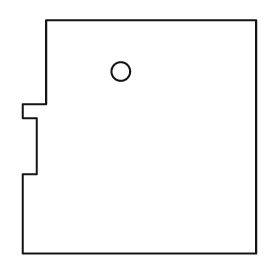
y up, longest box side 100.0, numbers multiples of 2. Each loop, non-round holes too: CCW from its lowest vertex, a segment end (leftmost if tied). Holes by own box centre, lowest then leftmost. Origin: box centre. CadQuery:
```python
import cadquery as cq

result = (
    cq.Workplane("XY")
    .moveTo(-50.0, -50.0)
    .lineTo(50.0, -50.0)
    .lineTo(50.0, 50.0)
    .lineTo(-40.0, 50.0)
    .lineTo(-40.0, 14.0)
    .lineTo(-50.0, 14.0)
    .lineTo(-50.0, 8.0)
    .lineTo(-44.0, 8.0)
    .lineTo(-44.0, -16.0)
    .lineTo(-50.0, -16.0)
    .close()
    .moveTo(-8.0, 28.0)
    .circle(4.0)
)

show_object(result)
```